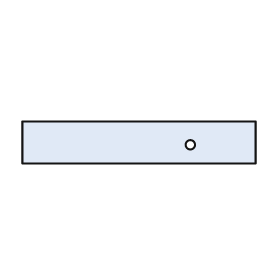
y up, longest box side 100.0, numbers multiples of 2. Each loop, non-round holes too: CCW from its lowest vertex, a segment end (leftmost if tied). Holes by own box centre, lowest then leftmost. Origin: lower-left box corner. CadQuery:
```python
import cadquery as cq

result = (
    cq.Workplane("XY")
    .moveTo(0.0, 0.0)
    .lineTo(100.0, 0.0)
    .lineTo(100.0, 18.0)
    .lineTo(0.0, 18.0)
    .close()
    .moveTo(72.0, 8.0)
    .circle(2.0)
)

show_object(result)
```